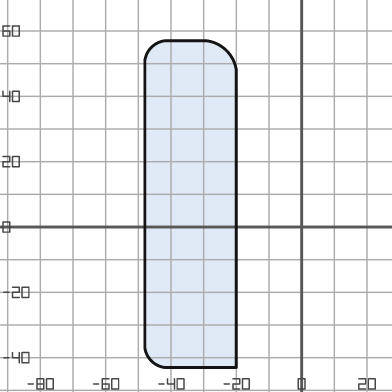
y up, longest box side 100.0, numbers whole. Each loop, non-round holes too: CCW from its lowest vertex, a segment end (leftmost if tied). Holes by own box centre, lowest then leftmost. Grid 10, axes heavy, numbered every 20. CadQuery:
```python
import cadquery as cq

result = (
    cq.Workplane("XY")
    .moveTo(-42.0, -43.0)
    .lineTo(-20.0, -43.0)
    .lineTo(-20.0, 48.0)
    .threePointArc((-23.0, 54.0), (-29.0, 57.0))
    .lineTo(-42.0, 57.0)
    .threePointArc((-46.0, 55.0), (-48.0, 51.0))
    .lineTo(-48.0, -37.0)
    .threePointArc((-46.0, -41.0), (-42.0, -43.0))
    .close()
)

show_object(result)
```